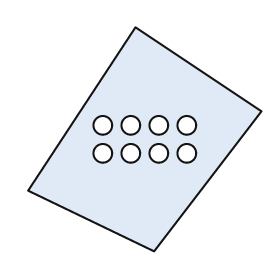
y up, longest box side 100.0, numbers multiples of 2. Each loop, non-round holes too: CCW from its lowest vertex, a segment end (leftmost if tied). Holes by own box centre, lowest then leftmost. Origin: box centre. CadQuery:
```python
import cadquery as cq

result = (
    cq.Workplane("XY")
    .moveTo(4.0, -48.0)
    .lineTo(50.0, 12.0)
    .lineTo(-4.0, 48.0)
    .lineTo(-50.0, -22.0)
    .close()
    .moveTo(-18.0, -6.0)
    .circle(4.0)
    .moveTo(-6.0, -6.0)
    .circle(4.0)
    .moveTo(6.0, -6.0)
    .circle(4.0)
    .moveTo(18.0, -6.0)
    .circle(4.0)
    .moveTo(-18.0, 6.0)
    .circle(4.0)
    .moveTo(-6.0, 6.0)
    .circle(4.0)
    .moveTo(6.0, 6.0)
    .circle(4.0)
    .moveTo(18.0, 6.0)
    .circle(4.0)
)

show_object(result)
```